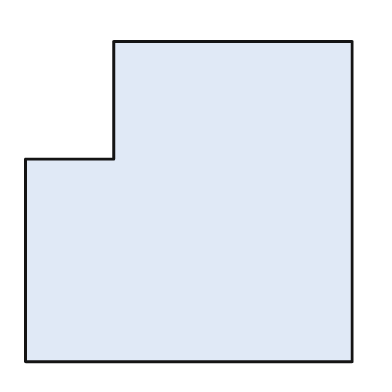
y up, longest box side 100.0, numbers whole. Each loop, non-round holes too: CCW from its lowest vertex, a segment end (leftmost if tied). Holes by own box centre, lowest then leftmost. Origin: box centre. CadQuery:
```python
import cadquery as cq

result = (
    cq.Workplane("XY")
    .moveTo(-50.0, -49.0)
    .lineTo(50.0, -49.0)
    .lineTo(50.0, 49.0)
    .lineTo(-23.0, 49.0)
    .lineTo(-23.0, 13.0)
    .lineTo(-50.0, 13.0)
    .close()
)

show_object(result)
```